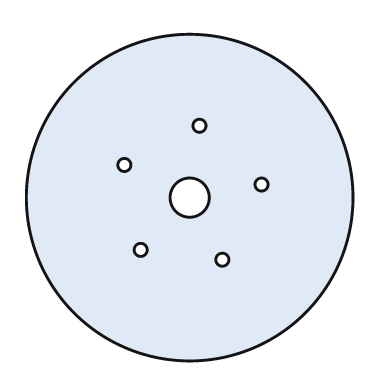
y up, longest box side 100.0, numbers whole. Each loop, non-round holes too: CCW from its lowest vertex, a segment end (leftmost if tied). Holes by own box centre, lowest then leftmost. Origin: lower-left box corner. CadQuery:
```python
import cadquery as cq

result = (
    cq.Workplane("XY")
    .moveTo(50.0, 50.0)
    .circle(50.0)
    .moveTo(60.0, 31.0)
    .circle(2.0)
    .moveTo(35.0, 34.0)
    .circle(2.0)
    .moveTo(50.0, 50.0)
    .circle(6.0)
    .moveTo(72.0, 54.0)
    .circle(2.0)
    .moveTo(30.0, 60.0)
    .circle(2.0)
    .moveTo(53.0, 72.0)
    .circle(2.0)
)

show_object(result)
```